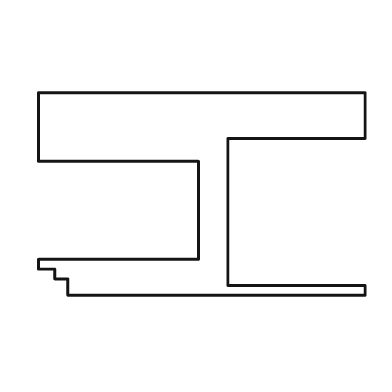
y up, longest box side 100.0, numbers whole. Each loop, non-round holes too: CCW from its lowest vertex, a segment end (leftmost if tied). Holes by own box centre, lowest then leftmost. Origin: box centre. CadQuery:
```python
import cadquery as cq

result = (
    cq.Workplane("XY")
    .moveTo(-41.0, -31.0)
    .lineTo(50.0, -31.0)
    .lineTo(50.0, -28.0)
    .lineTo(8.0, -28.0)
    .lineTo(8.0, 17.0)
    .lineTo(50.0, 17.0)
    .lineTo(50.0, 31.0)
    .lineTo(-50.0, 31.0)
    .lineTo(-50.0, 10.0)
    .lineTo(-1.0, 10.0)
    .lineTo(-1.0, -20.0)
    .lineTo(-50.0, -20.0)
    .lineTo(-50.0, -23.0)
    .lineTo(-45.0, -23.0)
    .lineTo(-45.0, -26.0)
    .lineTo(-41.0, -26.0)
    .close()
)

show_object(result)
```